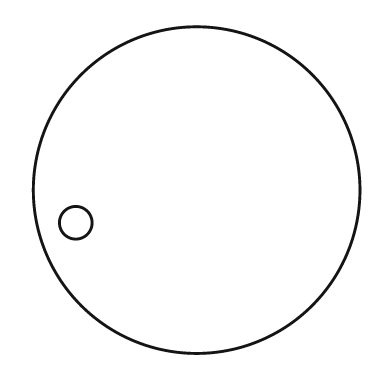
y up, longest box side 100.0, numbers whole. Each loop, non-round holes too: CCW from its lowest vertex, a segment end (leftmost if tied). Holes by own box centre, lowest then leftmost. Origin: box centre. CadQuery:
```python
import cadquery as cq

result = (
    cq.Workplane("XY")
    .moveTo(0.0, 0.0)
    .circle(50.0)
    .moveTo(-37.0, -10.0)
    .circle(5.0)
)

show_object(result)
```